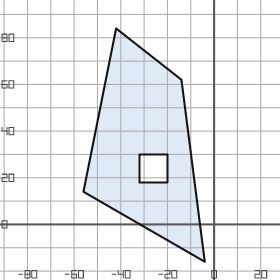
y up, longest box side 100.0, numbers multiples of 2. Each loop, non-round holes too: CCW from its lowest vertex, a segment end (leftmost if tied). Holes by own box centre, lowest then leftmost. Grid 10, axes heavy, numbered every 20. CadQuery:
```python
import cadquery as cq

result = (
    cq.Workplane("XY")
    .moveTo(-4.0, -16.0)
    .lineTo(-14.0, 62.0)
    .lineTo(-42.0, 84.0)
    .lineTo(-56.0, 14.0)
    .close()
    .moveTo(-32.0, 18.0)
    .lineTo(-20.0, 18.0)
    .lineTo(-20.0, 30.0)
    .lineTo(-32.0, 30.0)
    .close()
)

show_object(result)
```